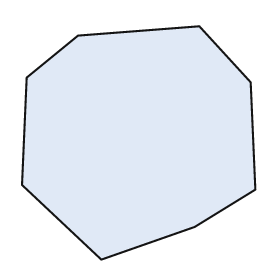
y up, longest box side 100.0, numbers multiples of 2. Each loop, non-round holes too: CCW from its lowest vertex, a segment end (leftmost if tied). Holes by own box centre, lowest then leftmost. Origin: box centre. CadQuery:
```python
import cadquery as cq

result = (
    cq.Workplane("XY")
    .moveTo(-16.0, -50.0)
    .lineTo(24.0, -36.0)
    .lineTo(50.0, -20.0)
    .lineTo(48.0, 26.0)
    .lineTo(26.0, 50.0)
    .lineTo(-26.0, 46.0)
    .lineTo(-48.0, 28.0)
    .lineTo(-50.0, -18.0)
    .close()
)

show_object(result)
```